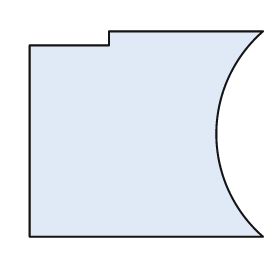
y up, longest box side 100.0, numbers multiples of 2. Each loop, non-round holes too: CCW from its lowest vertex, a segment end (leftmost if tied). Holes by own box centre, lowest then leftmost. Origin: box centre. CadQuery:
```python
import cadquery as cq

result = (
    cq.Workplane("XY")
    .moveTo(-50.0, -44.0)
    .lineTo(50.0, -44.0)
    .threePointArc((30.0, 0.0), (50.0, 44.0))
    .lineTo(-16.0, 44.0)
    .lineTo(-16.0, 38.0)
    .lineTo(-50.0, 38.0)
    .close()
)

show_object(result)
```